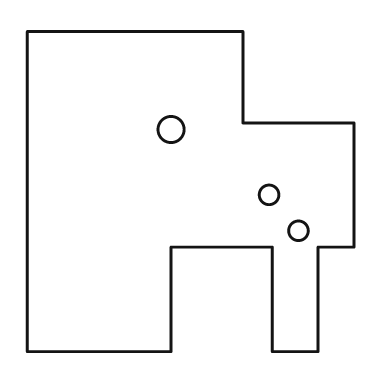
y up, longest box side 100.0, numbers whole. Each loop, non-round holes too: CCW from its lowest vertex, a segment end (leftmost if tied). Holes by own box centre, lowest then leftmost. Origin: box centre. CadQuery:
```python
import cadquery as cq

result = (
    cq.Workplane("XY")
    .moveTo(-50.0, -49.0)
    .lineTo(-6.0, -49.0)
    .lineTo(-6.0, -17.0)
    .lineTo(25.0, -17.0)
    .lineTo(25.0, -49.0)
    .lineTo(39.0, -49.0)
    .lineTo(39.0, -17.0)
    .lineTo(50.0, -17.0)
    .lineTo(50.0, 21.0)
    .lineTo(16.0, 21.0)
    .lineTo(16.0, 49.0)
    .lineTo(-50.0, 49.0)
    .close()
    .moveTo(33.0, -12.0)
    .circle(3.0)
    .moveTo(24.0, -1.0)
    .circle(3.0)
    .moveTo(-6.0, 19.0)
    .circle(4.0)
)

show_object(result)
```